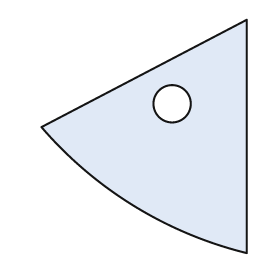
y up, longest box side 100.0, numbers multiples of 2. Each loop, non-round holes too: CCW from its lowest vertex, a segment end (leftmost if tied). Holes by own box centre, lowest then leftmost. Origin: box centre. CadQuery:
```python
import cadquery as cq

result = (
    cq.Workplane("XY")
    .moveTo(44.0, -50.0)
    .lineTo(44.0, 50.0)
    .lineTo(-44.0, 4.0)
    .threePointArc((-4.0, -30.0), (44.0, -50.0))
    .close()
    .moveTo(12.0, 14.0)
    .circle(8.0)
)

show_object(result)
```